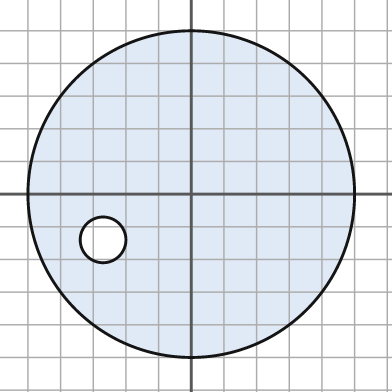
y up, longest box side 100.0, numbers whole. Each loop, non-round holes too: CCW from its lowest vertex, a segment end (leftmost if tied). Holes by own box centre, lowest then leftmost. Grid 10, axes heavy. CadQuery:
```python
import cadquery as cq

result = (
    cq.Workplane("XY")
    .moveTo(0.0, 0.0)
    .circle(50.0)
    .moveTo(-27.0, -14.0)
    .circle(7.0)
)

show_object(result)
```